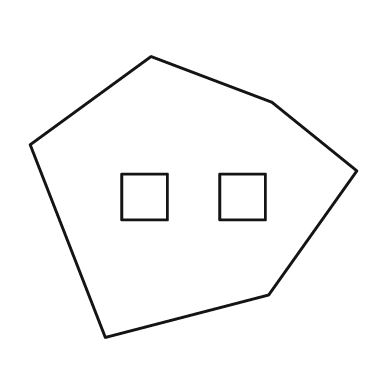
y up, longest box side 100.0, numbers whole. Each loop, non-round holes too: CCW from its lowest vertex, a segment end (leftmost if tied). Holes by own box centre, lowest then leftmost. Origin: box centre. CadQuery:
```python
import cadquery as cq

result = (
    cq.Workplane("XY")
    .moveTo(-27.0, -43.0)
    .lineTo(23.0, -30.0)
    .lineTo(50.0, 8.0)
    .lineTo(24.0, 29.0)
    .lineTo(-13.0, 43.0)
    .lineTo(-50.0, 16.0)
    .close()
    .moveTo(-22.0, -7.0)
    .lineTo(-8.0, -7.0)
    .lineTo(-8.0, 7.0)
    .lineTo(-22.0, 7.0)
    .close()
    .moveTo(8.0, -7.0)
    .lineTo(22.0, -7.0)
    .lineTo(22.0, 7.0)
    .lineTo(8.0, 7.0)
    .close()
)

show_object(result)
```